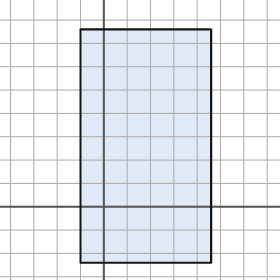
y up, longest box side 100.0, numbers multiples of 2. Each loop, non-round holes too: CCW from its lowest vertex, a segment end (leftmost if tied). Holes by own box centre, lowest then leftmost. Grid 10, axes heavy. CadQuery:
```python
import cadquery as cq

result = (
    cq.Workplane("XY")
    .moveTo(-10.0, -24.0)
    .lineTo(46.0, -24.0)
    .lineTo(46.0, 76.0)
    .lineTo(-10.0, 76.0)
    .close()
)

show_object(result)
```